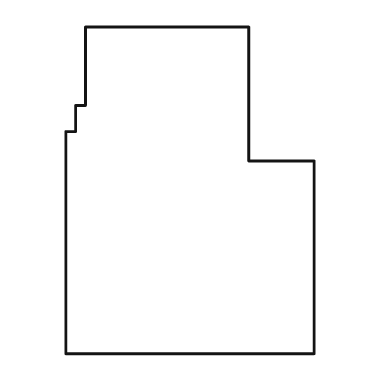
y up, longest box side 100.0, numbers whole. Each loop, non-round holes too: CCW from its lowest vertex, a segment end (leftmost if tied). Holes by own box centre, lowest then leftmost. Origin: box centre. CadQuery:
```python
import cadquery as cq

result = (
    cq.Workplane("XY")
    .moveTo(-38.0, -50.0)
    .lineTo(38.0, -50.0)
    .lineTo(38.0, 9.0)
    .lineTo(18.0, 9.0)
    .lineTo(18.0, 50.0)
    .lineTo(-32.0, 50.0)
    .lineTo(-32.0, 26.0)
    .lineTo(-35.0, 26.0)
    .lineTo(-35.0, 18.0)
    .lineTo(-38.0, 18.0)
    .close()
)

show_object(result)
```